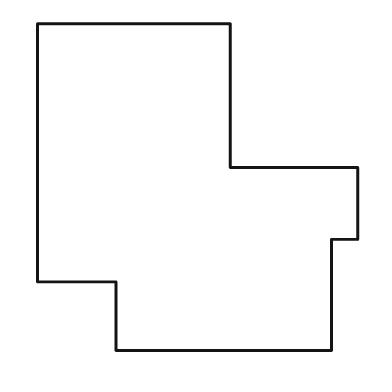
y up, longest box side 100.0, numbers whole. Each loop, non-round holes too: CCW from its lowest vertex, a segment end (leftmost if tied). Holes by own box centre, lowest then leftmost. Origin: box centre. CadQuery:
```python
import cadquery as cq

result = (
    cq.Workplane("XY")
    .moveTo(-25.0, -50.0)
    .lineTo(41.0, -50.0)
    .lineTo(41.0, -16.0)
    .lineTo(49.0, -16.0)
    .lineTo(49.0, 6.0)
    .lineTo(10.0, 6.0)
    .lineTo(10.0, 50.0)
    .lineTo(-49.0, 50.0)
    .lineTo(-49.0, -29.0)
    .lineTo(-25.0, -29.0)
    .close()
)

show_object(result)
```